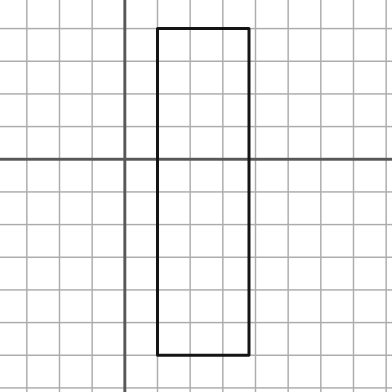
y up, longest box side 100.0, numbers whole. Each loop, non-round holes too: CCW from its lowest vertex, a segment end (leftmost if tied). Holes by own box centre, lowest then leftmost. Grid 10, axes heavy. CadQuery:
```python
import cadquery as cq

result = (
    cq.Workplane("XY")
    .moveTo(10.0, -60.0)
    .lineTo(38.0, -60.0)
    .lineTo(38.0, 40.0)
    .lineTo(10.0, 40.0)
    .close()
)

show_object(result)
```